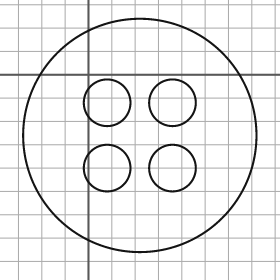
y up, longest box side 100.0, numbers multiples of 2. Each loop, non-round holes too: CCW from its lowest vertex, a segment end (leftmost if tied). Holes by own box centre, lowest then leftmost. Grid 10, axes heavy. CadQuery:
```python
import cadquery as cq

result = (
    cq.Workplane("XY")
    .moveTo(22.0, -26.0)
    .circle(50.0)
    .moveTo(8.0, -40.0)
    .circle(10.0)
    .moveTo(36.0, -40.0)
    .circle(10.0)
    .moveTo(8.0, -12.0)
    .circle(10.0)
    .moveTo(36.0, -12.0)
    .circle(10.0)
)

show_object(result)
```